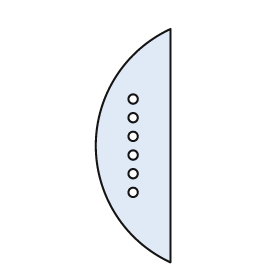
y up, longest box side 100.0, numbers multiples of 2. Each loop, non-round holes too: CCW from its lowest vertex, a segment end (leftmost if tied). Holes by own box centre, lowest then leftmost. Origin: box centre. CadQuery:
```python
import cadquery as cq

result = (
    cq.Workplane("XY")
    .moveTo(16.0, -50.0)
    .lineTo(16.0, 50.0)
    .threePointArc((-16.0, 0.0), (16.0, -50.0))
    .close()
    .moveTo(0.0, -20.0)
    .circle(2.0)
    .moveTo(0.0, -12.0)
    .circle(2.0)
    .moveTo(0.0, -4.0)
    .circle(2.0)
    .moveTo(0.0, 4.0)
    .circle(2.0)
    .moveTo(0.0, 12.0)
    .circle(2.0)
    .moveTo(0.0, 20.0)
    .circle(2.0)
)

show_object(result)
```